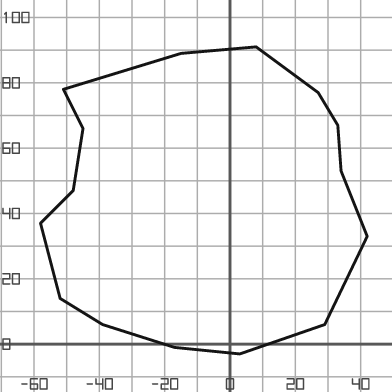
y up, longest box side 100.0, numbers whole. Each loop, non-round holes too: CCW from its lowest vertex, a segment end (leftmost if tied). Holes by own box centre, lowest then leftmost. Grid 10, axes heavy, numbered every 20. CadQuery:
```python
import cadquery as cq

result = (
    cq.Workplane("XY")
    .moveTo(3.0, -3.0)
    .lineTo(29.0, 6.0)
    .lineTo(42.0, 33.0)
    .lineTo(34.0, 53.0)
    .lineTo(33.0, 67.0)
    .lineTo(27.0, 77.0)
    .lineTo(8.0, 91.0)
    .lineTo(-15.0, 89.0)
    .lineTo(-51.0, 78.0)
    .lineTo(-45.0, 66.0)
    .lineTo(-48.0, 47.0)
    .lineTo(-58.0, 37.0)
    .lineTo(-52.0, 14.0)
    .lineTo(-39.0, 6.0)
    .lineTo(-17.0, -1.0)
    .close()
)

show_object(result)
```